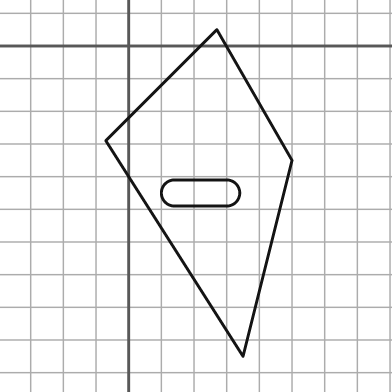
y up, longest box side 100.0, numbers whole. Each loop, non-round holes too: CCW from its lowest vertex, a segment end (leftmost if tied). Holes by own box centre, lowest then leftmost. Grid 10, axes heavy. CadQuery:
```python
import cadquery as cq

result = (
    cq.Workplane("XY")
    .moveTo(35.0, -95.0)
    .lineTo(50.0, -35.0)
    .lineTo(27.0, 5.0)
    .lineTo(-7.0, -29.0)
    .close()
    .moveTo(14.0, -49.0)
    .lineTo(30.0, -49.0)
    .threePointArc((34.0, -45.0), (30.0, -41.0))
    .lineTo(14.0, -41.0)
    .threePointArc((10.0, -45.0), (14.0, -49.0))
    .close()
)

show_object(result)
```